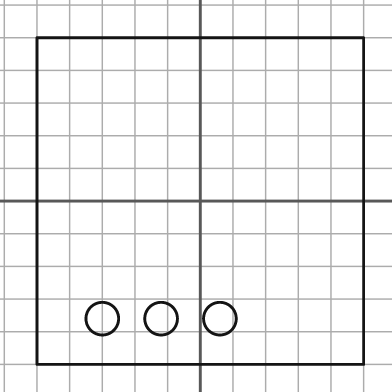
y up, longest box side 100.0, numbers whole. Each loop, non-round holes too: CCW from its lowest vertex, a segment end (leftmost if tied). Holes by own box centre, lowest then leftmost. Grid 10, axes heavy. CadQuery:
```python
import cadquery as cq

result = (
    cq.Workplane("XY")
    .moveTo(-50.0, -50.0)
    .lineTo(50.0, -50.0)
    .lineTo(50.0, 50.0)
    .lineTo(-50.0, 50.0)
    .close()
    .moveTo(-30.0, -36.0)
    .circle(5.0)
    .moveTo(-12.0, -36.0)
    .circle(5.0)
    .moveTo(6.0, -36.0)
    .circle(5.0)
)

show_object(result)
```